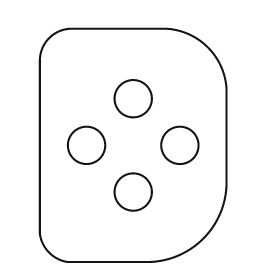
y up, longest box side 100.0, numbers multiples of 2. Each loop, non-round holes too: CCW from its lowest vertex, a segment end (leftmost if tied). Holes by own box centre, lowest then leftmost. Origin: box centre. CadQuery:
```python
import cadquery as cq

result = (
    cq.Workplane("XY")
    .moveTo(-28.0, -50.0)
    .lineTo(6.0, -50.0)
    .threePointArc((30.0, -40.0), (40.0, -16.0))
    .lineTo(40.0, 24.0)
    .threePointArc((32.0, 42.0), (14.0, 50.0))
    .lineTo(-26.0, 50.0)
    .threePointArc((-36.0, 46.0), (-40.0, 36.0))
    .lineTo(-40.0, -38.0)
    .threePointArc((-36.0, -46.0), (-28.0, -50.0))
    .close()
    .moveTo(0.0, -20.0)
    .circle(8.0)
    .moveTo(-20.0, 0.0)
    .circle(8.0)
    .moveTo(20.0, 0.0)
    .circle(8.0)
    .moveTo(0.0, 20.0)
    .circle(8.0)
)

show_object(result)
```